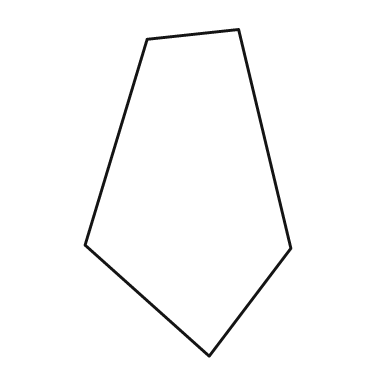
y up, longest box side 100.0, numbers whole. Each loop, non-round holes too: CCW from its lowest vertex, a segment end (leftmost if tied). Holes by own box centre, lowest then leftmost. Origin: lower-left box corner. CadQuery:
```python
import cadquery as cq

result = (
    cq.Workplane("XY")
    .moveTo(38.0, 0.0)
    .lineTo(63.0, 33.0)
    .lineTo(47.0, 100.0)
    .lineTo(19.0, 97.0)
    .lineTo(0.0, 34.0)
    .close()
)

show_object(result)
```